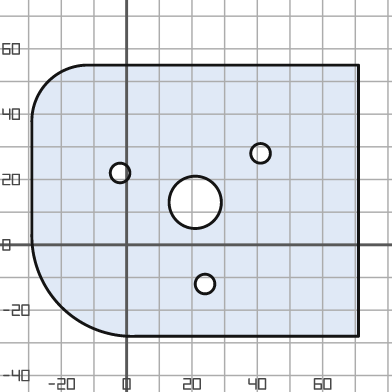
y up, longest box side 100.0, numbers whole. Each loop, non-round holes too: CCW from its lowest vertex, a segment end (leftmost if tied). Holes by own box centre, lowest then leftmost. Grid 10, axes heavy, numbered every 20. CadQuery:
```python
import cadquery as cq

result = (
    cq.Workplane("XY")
    .moveTo(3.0, -28.0)
    .lineTo(71.0, -28.0)
    .lineTo(71.0, 55.0)
    .lineTo(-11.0, 55.0)
    .threePointArc((-24.0, 50.0), (-29.0, 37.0))
    .lineTo(-29.0, 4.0)
    .threePointArc((-20.0, -19.0), (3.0, -28.0))
    .close()
    .moveTo(24.0, -12.0)
    .circle(3.0)
    .moveTo(21.0, 13.0)
    .circle(8.0)
    .moveTo(-2.0, 22.0)
    .circle(3.0)
    .moveTo(41.0, 28.0)
    .circle(3.0)
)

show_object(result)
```